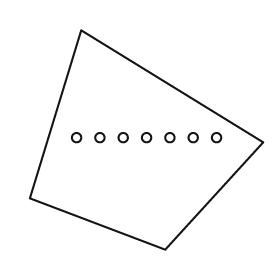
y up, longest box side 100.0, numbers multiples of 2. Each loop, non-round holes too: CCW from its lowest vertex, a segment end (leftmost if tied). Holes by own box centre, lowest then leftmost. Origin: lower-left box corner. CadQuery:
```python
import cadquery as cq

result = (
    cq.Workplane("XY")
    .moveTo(58.0, 0.0)
    .lineTo(100.0, 46.0)
    .lineTo(22.0, 94.0)
    .lineTo(0.0, 22.0)
    .close()
    .moveTo(20.0, 48.0)
    .circle(2.0)
    .moveTo(30.0, 48.0)
    .circle(2.0)
    .moveTo(40.0, 48.0)
    .circle(2.0)
    .moveTo(50.0, 48.0)
    .circle(2.0)
    .moveTo(60.0, 48.0)
    .circle(2.0)
    .moveTo(70.0, 48.0)
    .circle(2.0)
    .moveTo(80.0, 48.0)
    .circle(2.0)
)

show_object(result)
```